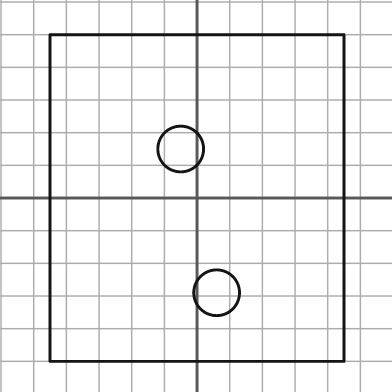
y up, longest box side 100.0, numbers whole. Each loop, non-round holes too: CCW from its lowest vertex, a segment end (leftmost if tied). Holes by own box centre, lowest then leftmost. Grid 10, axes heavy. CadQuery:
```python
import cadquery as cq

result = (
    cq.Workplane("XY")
    .moveTo(-45.0, -50.0)
    .lineTo(45.0, -50.0)
    .lineTo(45.0, 50.0)
    .lineTo(-45.0, 50.0)
    .close()
    .moveTo(6.0, -29.0)
    .circle(7.0)
    .moveTo(-5.0, 15.0)
    .circle(7.0)
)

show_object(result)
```